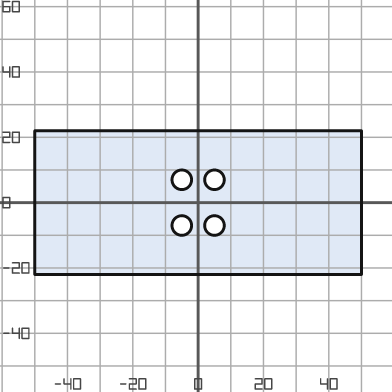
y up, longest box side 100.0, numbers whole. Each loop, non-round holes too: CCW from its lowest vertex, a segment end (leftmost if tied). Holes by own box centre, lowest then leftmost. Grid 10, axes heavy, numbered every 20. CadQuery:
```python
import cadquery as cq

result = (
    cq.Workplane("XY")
    .moveTo(-50.0, -22.0)
    .lineTo(50.0, -22.0)
    .lineTo(50.0, 22.0)
    .lineTo(-50.0, 22.0)
    .close()
    .moveTo(-5.0, -7.0)
    .circle(3.0)
    .moveTo(5.0, -7.0)
    .circle(3.0)
    .moveTo(-5.0, 7.0)
    .circle(3.0)
    .moveTo(5.0, 7.0)
    .circle(3.0)
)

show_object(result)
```